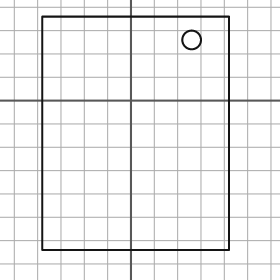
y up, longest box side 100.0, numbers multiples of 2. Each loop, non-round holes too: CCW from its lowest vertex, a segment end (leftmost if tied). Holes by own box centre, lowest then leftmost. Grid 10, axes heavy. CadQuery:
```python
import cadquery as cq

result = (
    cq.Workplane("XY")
    .moveTo(-38.0, -64.0)
    .lineTo(42.0, -64.0)
    .lineTo(42.0, 36.0)
    .lineTo(-38.0, 36.0)
    .close()
    .moveTo(26.0, 26.0)
    .circle(4.0)
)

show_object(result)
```